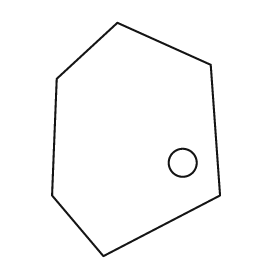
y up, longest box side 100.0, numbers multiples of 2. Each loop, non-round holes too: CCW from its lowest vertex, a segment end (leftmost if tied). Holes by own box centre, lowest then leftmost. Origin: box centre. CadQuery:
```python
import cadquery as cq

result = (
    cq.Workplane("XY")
    .moveTo(-14.0, -50.0)
    .lineTo(36.0, -24.0)
    .lineTo(32.0, 32.0)
    .lineTo(-8.0, 50.0)
    .lineTo(-34.0, 26.0)
    .lineTo(-36.0, -24.0)
    .close()
    .moveTo(20.0, -10.0)
    .circle(6.0)
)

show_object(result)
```